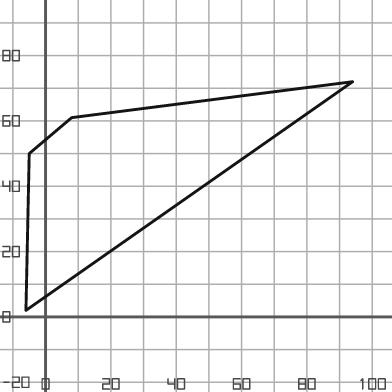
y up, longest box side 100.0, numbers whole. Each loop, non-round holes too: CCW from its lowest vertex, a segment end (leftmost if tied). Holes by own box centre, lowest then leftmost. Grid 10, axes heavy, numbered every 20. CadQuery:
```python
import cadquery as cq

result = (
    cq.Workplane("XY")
    .moveTo(-6.0, 2.0)
    .lineTo(94.0, 72.0)
    .lineTo(8.0, 61.0)
    .lineTo(-5.0, 50.0)
    .close()
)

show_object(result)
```